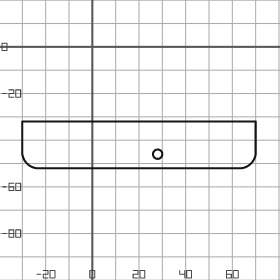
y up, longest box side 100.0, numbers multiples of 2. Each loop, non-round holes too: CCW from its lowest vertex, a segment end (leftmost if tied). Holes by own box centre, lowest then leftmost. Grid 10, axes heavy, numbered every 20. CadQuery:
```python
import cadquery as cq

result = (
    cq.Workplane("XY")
    .moveTo(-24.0, -52.0)
    .lineTo(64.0, -52.0)
    .threePointArc((68.0, -50.0), (70.0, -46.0))
    .lineTo(70.0, -32.0)
    .lineTo(-30.0, -32.0)
    .lineTo(-30.0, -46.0)
    .threePointArc((-28.0, -50.0), (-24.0, -52.0))
    .close()
    .moveTo(28.0, -46.0)
    .circle(2.0)
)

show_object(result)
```